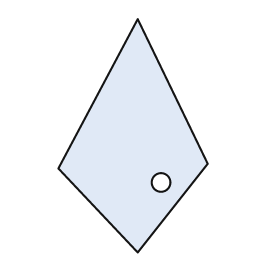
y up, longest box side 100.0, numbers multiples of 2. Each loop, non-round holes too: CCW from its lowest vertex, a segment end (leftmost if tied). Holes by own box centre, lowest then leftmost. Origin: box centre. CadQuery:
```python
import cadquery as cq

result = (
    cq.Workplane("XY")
    .moveTo(2.0, -50.0)
    .lineTo(32.0, -12.0)
    .lineTo(2.0, 50.0)
    .lineTo(-32.0, -14.0)
    .close()
    .moveTo(12.0, -20.0)
    .circle(4.0)
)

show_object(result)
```